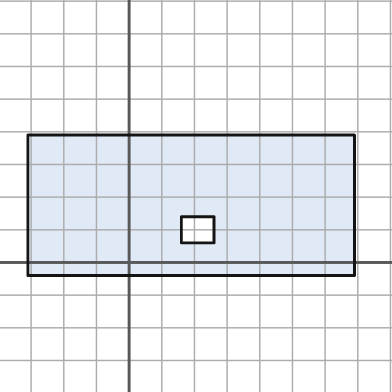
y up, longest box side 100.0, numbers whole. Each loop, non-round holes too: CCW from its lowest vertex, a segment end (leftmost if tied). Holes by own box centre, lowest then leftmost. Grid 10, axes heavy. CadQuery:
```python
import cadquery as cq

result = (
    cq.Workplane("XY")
    .moveTo(-31.0, -4.0)
    .lineTo(69.0, -4.0)
    .lineTo(69.0, 39.0)
    .lineTo(-31.0, 39.0)
    .close()
    .moveTo(16.0, 6.0)
    .lineTo(26.0, 6.0)
    .lineTo(26.0, 14.0)
    .lineTo(16.0, 14.0)
    .close()
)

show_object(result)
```